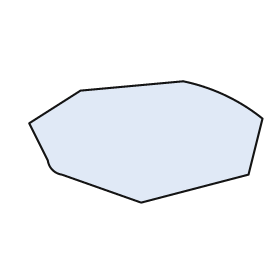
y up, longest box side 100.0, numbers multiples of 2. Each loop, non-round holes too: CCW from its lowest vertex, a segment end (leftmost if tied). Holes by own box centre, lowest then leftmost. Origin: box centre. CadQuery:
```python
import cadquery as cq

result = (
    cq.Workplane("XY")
    .moveTo(-2.0, -26.0)
    .lineTo(44.0, -14.0)
    .lineTo(50.0, 10.0)
    .threePointArc((34.0, 20.0), (16.0, 26.0))
    .lineTo(-28.0, 22.0)
    .lineTo(-50.0, 8.0)
    .lineTo(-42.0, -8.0)
    .threePointArc((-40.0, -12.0), (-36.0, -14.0))
    .close()
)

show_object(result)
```